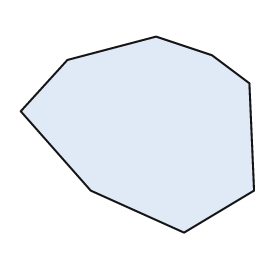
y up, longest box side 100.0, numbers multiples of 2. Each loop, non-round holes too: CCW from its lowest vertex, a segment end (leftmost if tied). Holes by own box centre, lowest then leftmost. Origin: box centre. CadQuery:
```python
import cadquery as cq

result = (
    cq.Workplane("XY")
    .moveTo(20.0, -42.0)
    .lineTo(50.0, -24.0)
    .lineTo(48.0, 22.0)
    .lineTo(32.0, 34.0)
    .lineTo(8.0, 42.0)
    .lineTo(-30.0, 32.0)
    .lineTo(-50.0, 10.0)
    .lineTo(-20.0, -24.0)
    .close()
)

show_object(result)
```